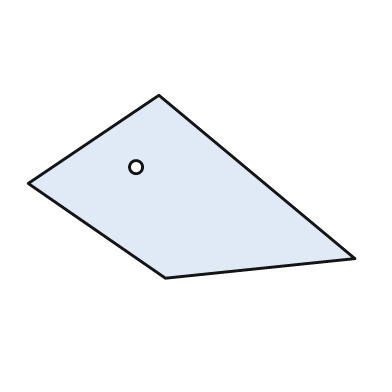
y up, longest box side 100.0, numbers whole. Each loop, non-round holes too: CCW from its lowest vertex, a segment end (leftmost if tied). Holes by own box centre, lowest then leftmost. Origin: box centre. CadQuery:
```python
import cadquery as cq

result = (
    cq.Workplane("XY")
    .moveTo(-8.0, -28.0)
    .lineTo(50.0, -22.0)
    .lineTo(-10.0, 28.0)
    .lineTo(-50.0, 1.0)
    .close()
    .moveTo(-17.0, 6.0)
    .circle(2.0)
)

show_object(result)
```